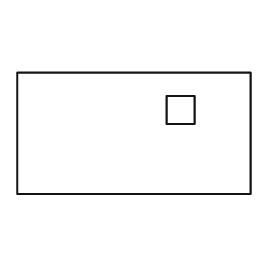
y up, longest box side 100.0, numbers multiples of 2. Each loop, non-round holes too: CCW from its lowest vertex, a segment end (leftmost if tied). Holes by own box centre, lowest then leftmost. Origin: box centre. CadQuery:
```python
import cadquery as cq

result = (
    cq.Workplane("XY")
    .moveTo(-50.0, -26.0)
    .lineTo(50.0, -26.0)
    .lineTo(50.0, 26.0)
    .lineTo(-50.0, 26.0)
    .close()
    .moveTo(14.0, 4.0)
    .lineTo(26.0, 4.0)
    .lineTo(26.0, 16.0)
    .lineTo(14.0, 16.0)
    .close()
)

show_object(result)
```